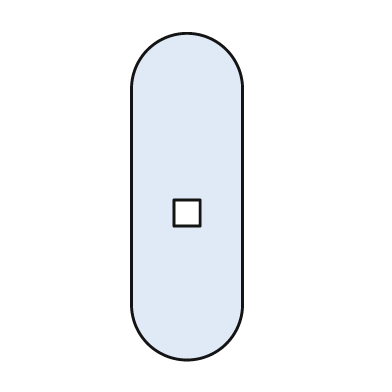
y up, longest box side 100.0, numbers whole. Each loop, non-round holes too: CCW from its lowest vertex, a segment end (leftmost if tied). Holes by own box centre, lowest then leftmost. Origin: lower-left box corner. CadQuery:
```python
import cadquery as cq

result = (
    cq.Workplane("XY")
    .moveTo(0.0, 17.0)
    .threePointArc((17.0, 0.0), (34.0, 17.0))
    .lineTo(34.0, 83.0)
    .threePointArc((17.0, 100.0), (0.0, 83.0))
    .close()
    .moveTo(13.0, 41.0)
    .lineTo(21.0, 41.0)
    .lineTo(21.0, 49.0)
    .lineTo(13.0, 49.0)
    .close()
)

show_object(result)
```